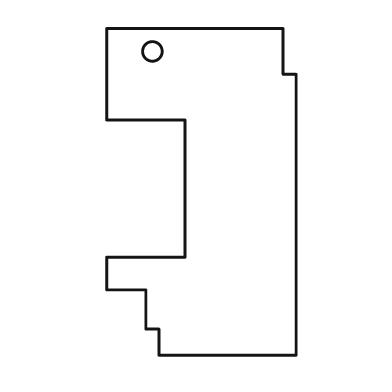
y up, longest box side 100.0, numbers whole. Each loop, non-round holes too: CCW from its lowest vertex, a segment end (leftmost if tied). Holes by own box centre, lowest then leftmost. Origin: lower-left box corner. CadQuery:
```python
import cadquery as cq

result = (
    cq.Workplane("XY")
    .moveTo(16.0, 0.0)
    .lineTo(58.0, 0.0)
    .lineTo(58.0, 86.0)
    .lineTo(54.0, 86.0)
    .lineTo(54.0, 100.0)
    .lineTo(0.0, 100.0)
    .lineTo(0.0, 72.0)
    .lineTo(24.0, 72.0)
    .lineTo(24.0, 30.0)
    .lineTo(0.0, 30.0)
    .lineTo(0.0, 20.0)
    .lineTo(12.0, 20.0)
    .lineTo(12.0, 8.0)
    .lineTo(16.0, 8.0)
    .close()
    .moveTo(14.0, 93.0)
    .circle(3.0)
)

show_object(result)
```